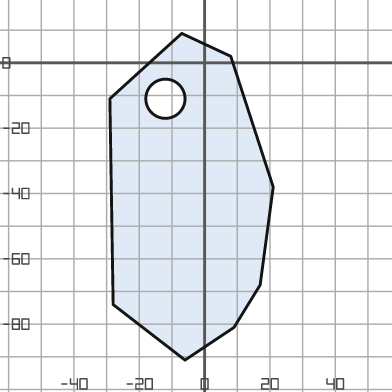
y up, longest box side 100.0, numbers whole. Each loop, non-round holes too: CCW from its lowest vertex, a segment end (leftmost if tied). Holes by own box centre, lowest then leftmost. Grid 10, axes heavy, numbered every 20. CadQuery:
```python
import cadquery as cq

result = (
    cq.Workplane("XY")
    .moveTo(-6.0, -91.0)
    .lineTo(9.0, -81.0)
    .lineTo(17.0, -68.0)
    .lineTo(21.0, -38.0)
    .lineTo(8.0, 2.0)
    .lineTo(-7.0, 9.0)
    .lineTo(-29.0, -11.0)
    .lineTo(-28.0, -74.0)
    .close()
    .moveTo(-12.0, -11.0)
    .circle(6.0)
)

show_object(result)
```